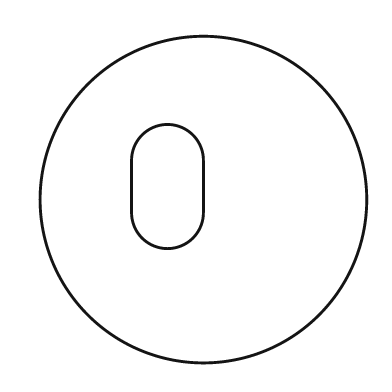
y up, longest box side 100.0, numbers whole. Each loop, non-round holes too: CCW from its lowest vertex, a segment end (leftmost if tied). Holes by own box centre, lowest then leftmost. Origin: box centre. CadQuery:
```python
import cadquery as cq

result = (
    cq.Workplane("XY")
    .moveTo(0.0, 0.0)
    .circle(50.0)
    .moveTo(-22.0, -4.0)
    .threePointArc((-11.0, -15.0), (0.0, -4.0))
    .lineTo(0.0, 12.0)
    .threePointArc((-11.0, 23.0), (-22.0, 12.0))
    .close()
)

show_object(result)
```